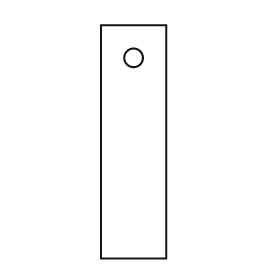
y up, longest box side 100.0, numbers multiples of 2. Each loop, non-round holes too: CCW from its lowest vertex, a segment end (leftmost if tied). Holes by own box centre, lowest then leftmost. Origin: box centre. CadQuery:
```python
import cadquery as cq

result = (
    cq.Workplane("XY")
    .moveTo(-14.0, -50.0)
    .lineTo(14.0, -50.0)
    .lineTo(14.0, 50.0)
    .lineTo(-14.0, 50.0)
    .close()
    .moveTo(0.0, 36.0)
    .circle(4.0)
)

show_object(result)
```